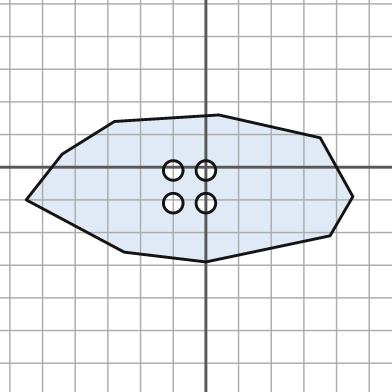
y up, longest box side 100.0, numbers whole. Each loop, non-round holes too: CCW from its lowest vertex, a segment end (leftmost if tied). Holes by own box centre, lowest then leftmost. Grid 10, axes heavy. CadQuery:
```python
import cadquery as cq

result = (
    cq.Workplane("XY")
    .moveTo(0.0, -29.0)
    .lineTo(38.0, -21.0)
    .lineTo(45.0, -9.0)
    .lineTo(35.0, 9.0)
    .lineTo(4.0, 16.0)
    .lineTo(-28.0, 14.0)
    .lineTo(-44.0, 4.0)
    .lineTo(-55.0, -10.0)
    .lineTo(-25.0, -26.0)
    .close()
    .moveTo(-10.0, -11.0)
    .circle(3.0)
    .moveTo(0.0, -11.0)
    .circle(3.0)
    .moveTo(-10.0, -1.0)
    .circle(3.0)
    .moveTo(0.0, -1.0)
    .circle(3.0)
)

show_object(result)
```